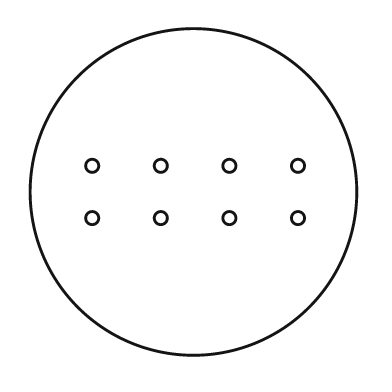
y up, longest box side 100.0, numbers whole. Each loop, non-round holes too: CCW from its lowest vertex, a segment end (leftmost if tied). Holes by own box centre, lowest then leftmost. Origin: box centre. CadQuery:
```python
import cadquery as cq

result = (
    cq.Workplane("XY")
    .moveTo(0.0, 0.0)
    .circle(50.0)
    .moveTo(-31.0, -8.0)
    .circle(2.0)
    .moveTo(-10.0, -8.0)
    .circle(2.0)
    .moveTo(11.0, -8.0)
    .circle(2.0)
    .moveTo(32.0, -8.0)
    .circle(2.0)
    .moveTo(-31.0, 8.0)
    .circle(2.0)
    .moveTo(-10.0, 8.0)
    .circle(2.0)
    .moveTo(11.0, 8.0)
    .circle(2.0)
    .moveTo(32.0, 8.0)
    .circle(2.0)
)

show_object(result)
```